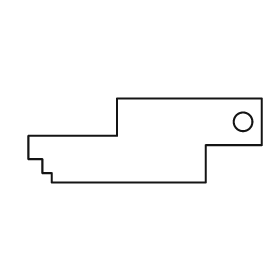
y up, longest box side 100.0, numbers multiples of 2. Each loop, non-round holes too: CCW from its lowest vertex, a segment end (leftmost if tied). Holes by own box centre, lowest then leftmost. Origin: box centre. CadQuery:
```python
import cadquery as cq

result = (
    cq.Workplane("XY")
    .moveTo(-40.0, -18.0)
    .lineTo(26.0, -18.0)
    .lineTo(26.0, -2.0)
    .lineTo(50.0, -2.0)
    .lineTo(50.0, 18.0)
    .lineTo(-12.0, 18.0)
    .lineTo(-12.0, 2.0)
    .lineTo(-50.0, 2.0)
    .lineTo(-50.0, -8.0)
    .lineTo(-44.0, -8.0)
    .lineTo(-44.0, -14.0)
    .lineTo(-40.0, -14.0)
    .close()
    .moveTo(42.0, 8.0)
    .circle(4.0)
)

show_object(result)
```